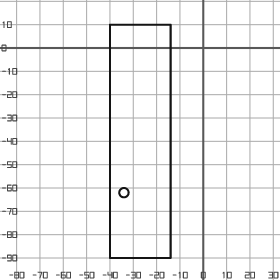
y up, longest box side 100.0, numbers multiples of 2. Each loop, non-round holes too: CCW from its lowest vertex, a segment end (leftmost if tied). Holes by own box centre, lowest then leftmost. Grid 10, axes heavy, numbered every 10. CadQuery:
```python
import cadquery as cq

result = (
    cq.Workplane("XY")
    .moveTo(-40.0, -90.0)
    .lineTo(-14.0, -90.0)
    .lineTo(-14.0, 10.0)
    .lineTo(-40.0, 10.0)
    .close()
    .moveTo(-34.0, -62.0)
    .circle(2.0)
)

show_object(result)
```